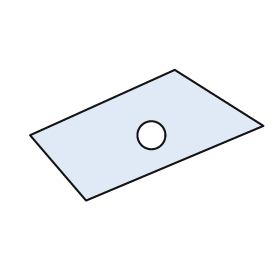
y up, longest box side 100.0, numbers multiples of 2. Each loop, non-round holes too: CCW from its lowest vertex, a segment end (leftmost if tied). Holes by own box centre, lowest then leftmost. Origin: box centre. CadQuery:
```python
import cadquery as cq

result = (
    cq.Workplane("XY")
    .moveTo(-26.0, -28.0)
    .lineTo(50.0, 4.0)
    .lineTo(12.0, 28.0)
    .lineTo(-50.0, 0.0)
    .close()
    .moveTo(2.0, 0.0)
    .circle(6.0)
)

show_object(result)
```